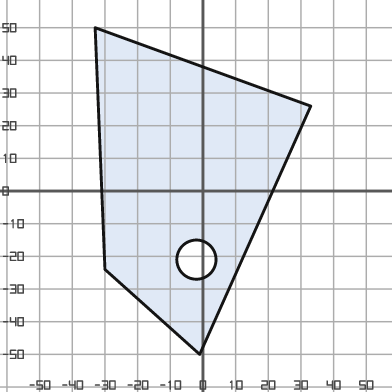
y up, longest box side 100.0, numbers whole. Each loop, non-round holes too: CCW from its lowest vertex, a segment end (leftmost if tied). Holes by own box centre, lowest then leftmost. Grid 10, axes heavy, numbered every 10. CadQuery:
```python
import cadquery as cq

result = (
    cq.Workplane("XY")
    .moveTo(-1.0, -50.0)
    .lineTo(33.0, 26.0)
    .lineTo(-33.0, 50.0)
    .lineTo(-30.0, -24.0)
    .close()
    .moveTo(-2.0, -21.0)
    .circle(6.0)
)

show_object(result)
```